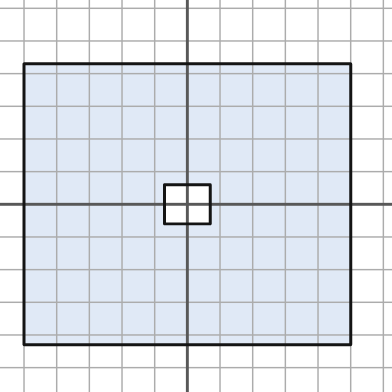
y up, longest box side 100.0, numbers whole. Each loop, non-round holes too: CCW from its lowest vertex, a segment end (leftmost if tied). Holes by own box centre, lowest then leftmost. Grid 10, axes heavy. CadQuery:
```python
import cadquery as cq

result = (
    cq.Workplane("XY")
    .moveTo(-50.0, -43.0)
    .lineTo(50.0, -43.0)
    .lineTo(50.0, 43.0)
    .lineTo(-50.0, 43.0)
    .close()
    .moveTo(-7.0, -6.0)
    .lineTo(7.0, -6.0)
    .lineTo(7.0, 6.0)
    .lineTo(-7.0, 6.0)
    .close()
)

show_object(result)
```